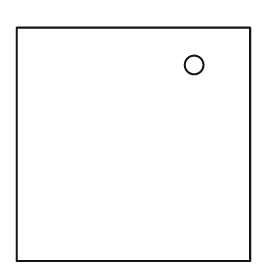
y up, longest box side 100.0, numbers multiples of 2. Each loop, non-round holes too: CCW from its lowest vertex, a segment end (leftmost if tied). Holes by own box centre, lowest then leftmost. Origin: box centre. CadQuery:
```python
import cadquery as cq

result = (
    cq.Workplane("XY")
    .moveTo(-50.0, -50.0)
    .lineTo(50.0, -50.0)
    .lineTo(50.0, 50.0)
    .lineTo(-50.0, 50.0)
    .close()
    .moveTo(26.0, 34.0)
    .circle(4.0)
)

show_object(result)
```